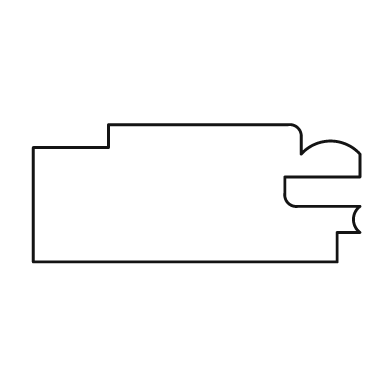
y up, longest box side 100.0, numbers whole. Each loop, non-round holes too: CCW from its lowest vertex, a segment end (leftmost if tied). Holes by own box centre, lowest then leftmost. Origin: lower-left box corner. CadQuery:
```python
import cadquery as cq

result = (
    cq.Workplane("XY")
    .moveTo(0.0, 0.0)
    .lineTo(93.0, 0.0)
    .lineTo(93.0, 9.0)
    .lineTo(100.0, 9.0)
    .threePointArc((98.0, 13.0), (100.0, 17.0))
    .lineTo(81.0, 17.0)
    .threePointArc((78.0, 18.0), (77.0, 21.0))
    .lineTo(77.0, 26.0)
    .lineTo(100.0, 26.0)
    .lineTo(100.0, 33.0)
    .threePointArc((91.0, 37.0), (82.0, 33.0))
    .lineTo(82.0, 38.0)
    .threePointArc((81.0, 41.0), (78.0, 42.0))
    .lineTo(23.0, 42.0)
    .lineTo(23.0, 35.0)
    .lineTo(0.0, 35.0)
    .close()
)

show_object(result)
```